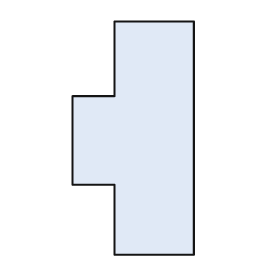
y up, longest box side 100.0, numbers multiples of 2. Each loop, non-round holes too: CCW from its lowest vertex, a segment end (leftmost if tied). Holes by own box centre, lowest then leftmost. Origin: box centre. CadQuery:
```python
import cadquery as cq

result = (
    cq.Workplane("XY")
    .moveTo(-8.0, -50.0)
    .lineTo(26.0, -50.0)
    .lineTo(26.0, 50.0)
    .lineTo(-8.0, 50.0)
    .lineTo(-8.0, 18.0)
    .lineTo(-26.0, 18.0)
    .lineTo(-26.0, -20.0)
    .lineTo(-8.0, -20.0)
    .close()
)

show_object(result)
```